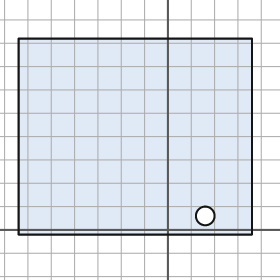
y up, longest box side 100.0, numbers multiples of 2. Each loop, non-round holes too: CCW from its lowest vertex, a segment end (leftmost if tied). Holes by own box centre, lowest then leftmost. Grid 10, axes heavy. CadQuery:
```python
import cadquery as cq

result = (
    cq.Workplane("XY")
    .moveTo(-64.0, -2.0)
    .lineTo(36.0, -2.0)
    .lineTo(36.0, 82.0)
    .lineTo(-64.0, 82.0)
    .close()
    .moveTo(16.0, 6.0)
    .circle(4.0)
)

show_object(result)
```